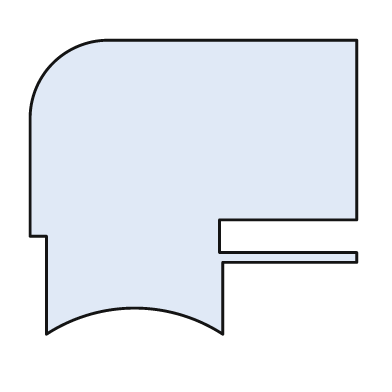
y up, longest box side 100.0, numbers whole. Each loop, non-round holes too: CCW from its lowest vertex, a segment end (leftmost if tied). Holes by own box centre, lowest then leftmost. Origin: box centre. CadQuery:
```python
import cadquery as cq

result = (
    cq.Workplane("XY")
    .moveTo(-45.0, -45.0)
    .threePointArc((-18.0, -37.0), (9.0, -45.0))
    .lineTo(9.0, -23.0)
    .lineTo(50.0, -23.0)
    .lineTo(50.0, -20.0)
    .lineTo(8.0, -20.0)
    .lineTo(8.0, -10.0)
    .lineTo(50.0, -10.0)
    .lineTo(50.0, 45.0)
    .lineTo(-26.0, 45.0)
    .threePointArc((-43.0, 38.0), (-50.0, 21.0))
    .lineTo(-50.0, -15.0)
    .lineTo(-45.0, -15.0)
    .close()
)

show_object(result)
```